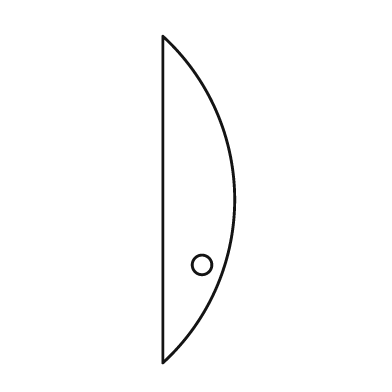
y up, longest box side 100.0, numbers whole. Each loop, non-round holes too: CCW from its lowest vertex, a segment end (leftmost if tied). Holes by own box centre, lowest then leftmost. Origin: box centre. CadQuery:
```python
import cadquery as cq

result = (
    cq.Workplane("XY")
    .moveTo(-11.0, -50.0)
    .threePointArc((11.0, 0.0), (-11.0, 50.0))
    .close()
    .moveTo(1.0, -20.0)
    .circle(3.0)
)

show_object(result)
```